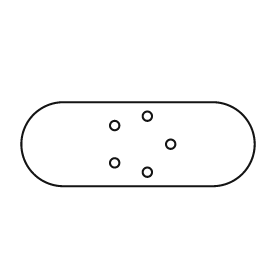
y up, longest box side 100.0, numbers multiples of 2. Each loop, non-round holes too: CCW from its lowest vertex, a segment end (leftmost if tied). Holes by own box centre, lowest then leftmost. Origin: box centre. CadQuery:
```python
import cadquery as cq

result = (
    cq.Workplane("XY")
    .moveTo(-32.0, -18.0)
    .lineTo(32.0, -18.0)
    .threePointArc((50.0, 0.0), (32.0, 18.0))
    .lineTo(-32.0, 18.0)
    .threePointArc((-50.0, 0.0), (-32.0, -18.0))
    .close()
    .moveTo(4.0, -12.0)
    .circle(2.0)
    .moveTo(-10.0, -8.0)
    .circle(2.0)
    .moveTo(14.0, 0.0)
    .circle(2.0)
    .moveTo(-10.0, 8.0)
    .circle(2.0)
    .moveTo(4.0, 12.0)
    .circle(2.0)
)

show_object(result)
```